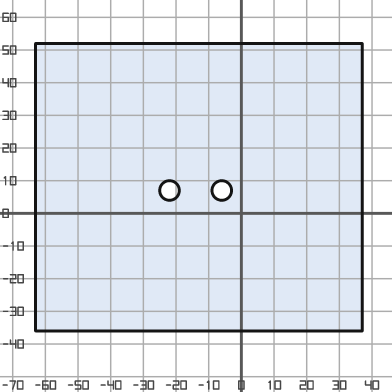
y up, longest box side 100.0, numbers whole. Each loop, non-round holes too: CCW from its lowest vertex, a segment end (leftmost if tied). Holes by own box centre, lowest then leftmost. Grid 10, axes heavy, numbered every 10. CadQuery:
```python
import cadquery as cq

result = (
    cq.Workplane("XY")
    .moveTo(-63.0, -36.0)
    .lineTo(37.0, -36.0)
    .lineTo(37.0, 52.0)
    .lineTo(-63.0, 52.0)
    .close()
    .moveTo(-22.0, 7.0)
    .circle(3.0)
    .moveTo(-6.0, 7.0)
    .circle(3.0)
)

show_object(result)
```